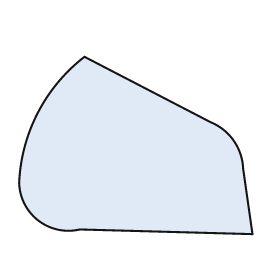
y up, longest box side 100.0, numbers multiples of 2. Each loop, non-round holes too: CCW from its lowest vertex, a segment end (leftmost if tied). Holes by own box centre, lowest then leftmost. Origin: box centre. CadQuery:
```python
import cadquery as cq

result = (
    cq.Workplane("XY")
    .moveTo(50.0, -38.0)
    .lineTo(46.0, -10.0)
    .threePointArc((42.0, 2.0), (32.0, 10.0))
    .lineTo(-22.0, 38.0)
    .threePointArc((-42.0, 14.0), (-50.0, -16.0))
    .threePointArc((-42.0, -32.0), (-24.0, -36.0))
    .close()
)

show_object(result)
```